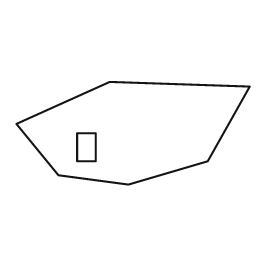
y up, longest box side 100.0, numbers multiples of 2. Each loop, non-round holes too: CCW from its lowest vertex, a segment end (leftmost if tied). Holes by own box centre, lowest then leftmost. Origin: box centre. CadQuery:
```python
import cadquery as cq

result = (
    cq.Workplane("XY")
    .moveTo(-2.0, -22.0)
    .lineTo(32.0, -12.0)
    .lineTo(50.0, 20.0)
    .lineTo(-10.0, 22.0)
    .lineTo(-50.0, 4.0)
    .lineTo(-32.0, -18.0)
    .close()
    .moveTo(-24.0, -12.0)
    .lineTo(-16.0, -12.0)
    .lineTo(-16.0, 0.0)
    .lineTo(-24.0, 0.0)
    .close()
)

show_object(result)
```